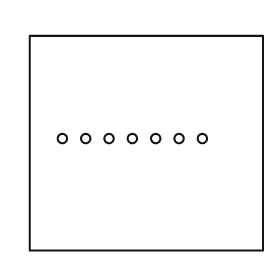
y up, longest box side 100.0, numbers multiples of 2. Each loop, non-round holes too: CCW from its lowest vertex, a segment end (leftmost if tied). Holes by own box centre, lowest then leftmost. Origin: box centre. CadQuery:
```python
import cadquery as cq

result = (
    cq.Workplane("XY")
    .moveTo(-50.0, -46.0)
    .lineTo(50.0, -46.0)
    .lineTo(50.0, 46.0)
    .lineTo(-50.0, 46.0)
    .close()
    .moveTo(-36.0, 2.0)
    .circle(2.0)
    .moveTo(-26.0, 2.0)
    .circle(2.0)
    .moveTo(-16.0, 2.0)
    .circle(2.0)
    .moveTo(-6.0, 2.0)
    .circle(2.0)
    .moveTo(4.0, 2.0)
    .circle(2.0)
    .moveTo(14.0, 2.0)
    .circle(2.0)
    .moveTo(24.0, 2.0)
    .circle(2.0)
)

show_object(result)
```